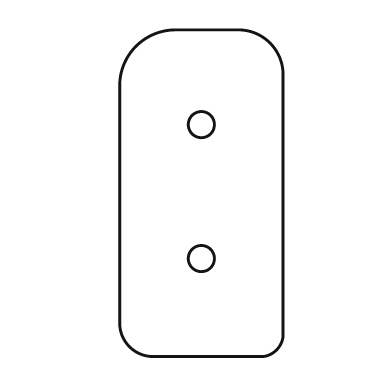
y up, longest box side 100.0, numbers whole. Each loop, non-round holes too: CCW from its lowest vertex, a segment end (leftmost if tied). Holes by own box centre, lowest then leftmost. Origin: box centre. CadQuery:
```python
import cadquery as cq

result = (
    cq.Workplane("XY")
    .moveTo(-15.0, -50.0)
    .lineTo(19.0, -50.0)
    .threePointArc((23.0, -48.0), (25.0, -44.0))
    .lineTo(25.0, 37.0)
    .threePointArc((21.0, 46.0), (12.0, 50.0))
    .lineTo(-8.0, 50.0)
    .threePointArc((-20.0, 45.0), (-25.0, 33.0))
    .lineTo(-25.0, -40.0)
    .threePointArc((-22.0, -47.0), (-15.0, -50.0))
    .close()
    .moveTo(0.0, -20.0)
    .circle(4.0)
    .moveTo(0.0, 21.0)
    .circle(4.0)
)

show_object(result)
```